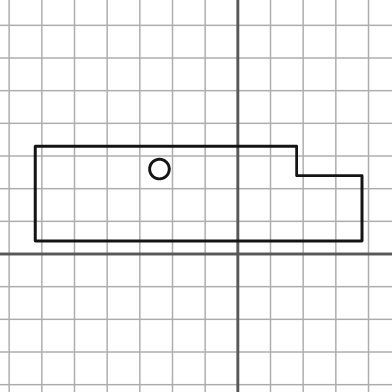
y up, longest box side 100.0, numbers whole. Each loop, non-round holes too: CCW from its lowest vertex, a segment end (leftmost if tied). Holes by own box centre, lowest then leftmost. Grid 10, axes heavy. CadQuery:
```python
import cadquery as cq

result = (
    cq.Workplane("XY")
    .moveTo(-62.0, 4.0)
    .lineTo(38.0, 4.0)
    .lineTo(38.0, 24.0)
    .lineTo(18.0, 24.0)
    .lineTo(18.0, 33.0)
    .lineTo(-62.0, 33.0)
    .close()
    .moveTo(-24.0, 26.0)
    .circle(3.0)
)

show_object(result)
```